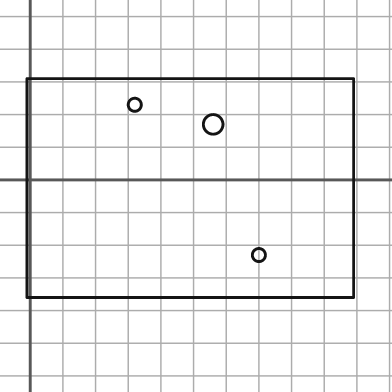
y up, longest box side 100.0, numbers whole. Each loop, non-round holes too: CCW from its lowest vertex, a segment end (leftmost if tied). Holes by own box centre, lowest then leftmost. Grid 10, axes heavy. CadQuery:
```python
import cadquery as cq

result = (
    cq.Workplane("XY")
    .moveTo(-1.0, -36.0)
    .lineTo(99.0, -36.0)
    .lineTo(99.0, 31.0)
    .lineTo(-1.0, 31.0)
    .close()
    .moveTo(70.0, -23.0)
    .circle(2.0)
    .moveTo(56.0, 17.0)
    .circle(3.0)
    .moveTo(32.0, 23.0)
    .circle(2.0)
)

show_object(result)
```